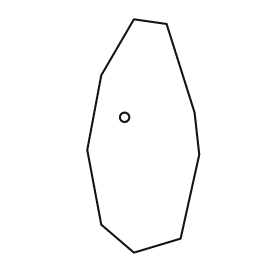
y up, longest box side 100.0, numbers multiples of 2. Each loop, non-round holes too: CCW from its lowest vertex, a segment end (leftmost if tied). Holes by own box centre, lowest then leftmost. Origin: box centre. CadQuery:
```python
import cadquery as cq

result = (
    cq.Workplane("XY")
    .moveTo(-4.0, -50.0)
    .lineTo(16.0, -44.0)
    .lineTo(24.0, -8.0)
    .lineTo(22.0, 10.0)
    .lineTo(10.0, 48.0)
    .lineTo(-4.0, 50.0)
    .lineTo(-18.0, 26.0)
    .lineTo(-24.0, -6.0)
    .lineTo(-18.0, -38.0)
    .close()
    .moveTo(-8.0, 8.0)
    .circle(2.0)
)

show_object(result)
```